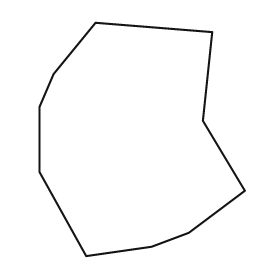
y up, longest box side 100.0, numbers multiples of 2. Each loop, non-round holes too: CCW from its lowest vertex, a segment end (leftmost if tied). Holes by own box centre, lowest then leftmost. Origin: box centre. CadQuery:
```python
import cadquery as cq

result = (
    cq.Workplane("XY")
    .moveTo(-24.0, -50.0)
    .lineTo(4.0, -46.0)
    .lineTo(20.0, -40.0)
    .lineTo(44.0, -22.0)
    .lineTo(26.0, 8.0)
    .lineTo(30.0, 46.0)
    .lineTo(-20.0, 50.0)
    .lineTo(-38.0, 28.0)
    .lineTo(-44.0, 14.0)
    .lineTo(-44.0, -14.0)
    .close()
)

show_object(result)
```